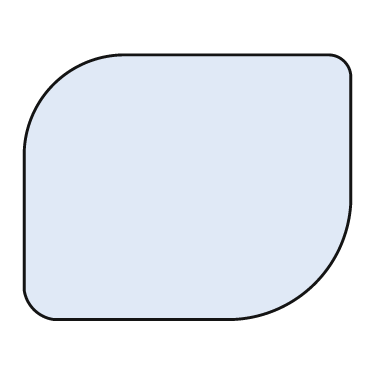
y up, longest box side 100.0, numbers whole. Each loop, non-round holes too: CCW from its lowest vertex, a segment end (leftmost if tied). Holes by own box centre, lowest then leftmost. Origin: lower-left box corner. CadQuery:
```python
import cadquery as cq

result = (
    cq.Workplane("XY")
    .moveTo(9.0, 0.0)
    .lineTo(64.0, 0.0)
    .threePointArc((89.0, 11.0), (100.0, 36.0))
    .lineTo(100.0, 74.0)
    .threePointArc((98.0, 79.0), (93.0, 81.0))
    .lineTo(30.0, 81.0)
    .threePointArc((9.0, 72.0), (0.0, 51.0))
    .lineTo(0.0, 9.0)
    .threePointArc((3.0, 3.0), (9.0, 0.0))
    .close()
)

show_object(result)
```